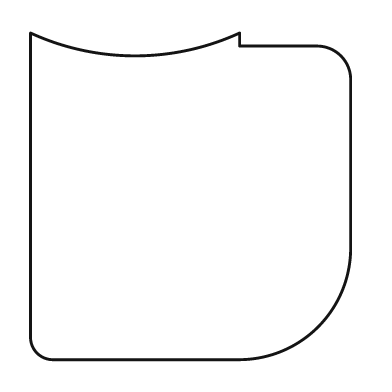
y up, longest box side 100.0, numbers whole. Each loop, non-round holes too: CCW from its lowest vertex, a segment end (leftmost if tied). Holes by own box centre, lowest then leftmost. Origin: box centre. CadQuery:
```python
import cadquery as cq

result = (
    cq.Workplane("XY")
    .moveTo(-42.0, -50.0)
    .lineTo(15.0, -50.0)
    .threePointArc((39.0, -40.0), (49.0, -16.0))
    .lineTo(49.0, 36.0)
    .threePointArc((46.0, 43.0), (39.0, 46.0))
    .lineTo(15.0, 46.0)
    .lineTo(15.0, 50.0)
    .threePointArc((-17.0, 43.0), (-49.0, 50.0))
    .lineTo(-49.0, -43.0)
    .threePointArc((-47.0, -48.0), (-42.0, -50.0))
    .close()
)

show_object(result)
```